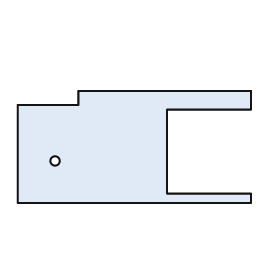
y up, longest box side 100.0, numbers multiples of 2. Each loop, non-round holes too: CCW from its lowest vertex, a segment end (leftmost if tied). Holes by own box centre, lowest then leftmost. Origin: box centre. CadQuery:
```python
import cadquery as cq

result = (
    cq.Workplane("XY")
    .moveTo(-50.0, -24.0)
    .lineTo(50.0, -24.0)
    .lineTo(50.0, -20.0)
    .lineTo(14.0, -20.0)
    .lineTo(14.0, 16.0)
    .lineTo(50.0, 16.0)
    .lineTo(50.0, 24.0)
    .lineTo(-24.0, 24.0)
    .lineTo(-24.0, 18.0)
    .lineTo(-50.0, 18.0)
    .close()
    .moveTo(-34.0, -6.0)
    .circle(2.0)
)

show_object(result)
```